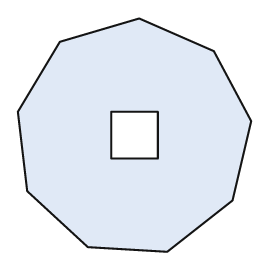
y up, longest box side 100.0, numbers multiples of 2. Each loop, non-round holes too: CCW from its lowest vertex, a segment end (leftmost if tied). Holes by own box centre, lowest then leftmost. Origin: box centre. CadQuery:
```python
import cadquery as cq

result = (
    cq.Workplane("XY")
    .moveTo(14.0, -50.0)
    .lineTo(42.0, -28.0)
    .lineTo(50.0, 6.0)
    .lineTo(34.0, 36.0)
    .lineTo(2.0, 50.0)
    .lineTo(-32.0, 40.0)
    .lineTo(-50.0, 10.0)
    .lineTo(-46.0, -24.0)
    .lineTo(-20.0, -48.0)
    .close()
    .moveTo(-10.0, -10.0)
    .lineTo(10.0, -10.0)
    .lineTo(10.0, 10.0)
    .lineTo(-10.0, 10.0)
    .close()
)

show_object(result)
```